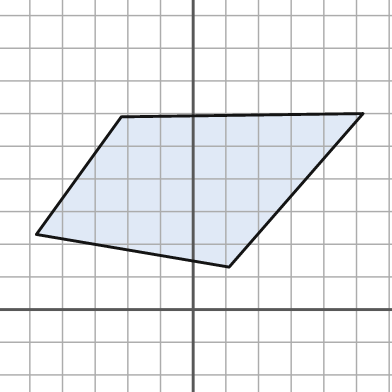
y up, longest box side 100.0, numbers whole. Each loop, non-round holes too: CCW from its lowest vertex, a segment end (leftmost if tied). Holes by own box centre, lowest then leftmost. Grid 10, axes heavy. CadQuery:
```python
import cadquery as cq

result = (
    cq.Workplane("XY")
    .moveTo(11.0, 13.0)
    .lineTo(52.0, 60.0)
    .lineTo(-22.0, 59.0)
    .lineTo(-48.0, 23.0)
    .close()
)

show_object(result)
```